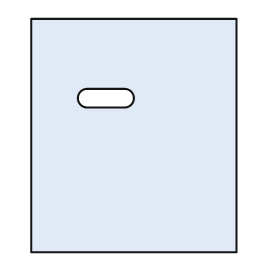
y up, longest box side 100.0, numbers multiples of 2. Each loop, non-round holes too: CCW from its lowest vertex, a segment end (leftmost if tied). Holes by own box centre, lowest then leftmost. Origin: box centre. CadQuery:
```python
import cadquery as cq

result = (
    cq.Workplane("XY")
    .moveTo(-44.0, -50.0)
    .lineTo(44.0, -50.0)
    .lineTo(44.0, 50.0)
    .lineTo(-44.0, 50.0)
    .close()
    .moveTo(-20.0, 12.0)
    .lineTo(-4.0, 12.0)
    .threePointArc((0.0, 16.0), (-4.0, 20.0))
    .lineTo(-20.0, 20.0)
    .threePointArc((-24.0, 16.0), (-20.0, 12.0))
    .close()
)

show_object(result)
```